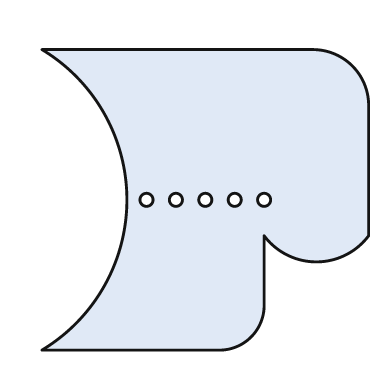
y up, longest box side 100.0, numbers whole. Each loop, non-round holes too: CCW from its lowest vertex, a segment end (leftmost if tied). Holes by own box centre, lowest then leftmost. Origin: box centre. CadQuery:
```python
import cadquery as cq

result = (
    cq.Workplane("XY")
    .moveTo(-50.0, -46.0)
    .lineTo(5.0, -46.0)
    .threePointArc((14.0, -42.0), (18.0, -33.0))
    .lineTo(18.0, -11.0)
    .threePointArc((34.0, -19.0), (50.0, -11.0))
    .lineTo(50.0, 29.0)
    .threePointArc((45.0, 41.0), (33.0, 46.0))
    .lineTo(-50.0, 46.0)
    .threePointArc((-24.0, 0.0), (-50.0, -46.0))
    .close()
    .moveTo(-18.0, 0.0)
    .circle(2.0)
    .moveTo(-9.0, 0.0)
    .circle(2.0)
    .moveTo(0.0, 0.0)
    .circle(2.0)
    .moveTo(9.0, 0.0)
    .circle(2.0)
    .moveTo(18.0, 0.0)
    .circle(2.0)
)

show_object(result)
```